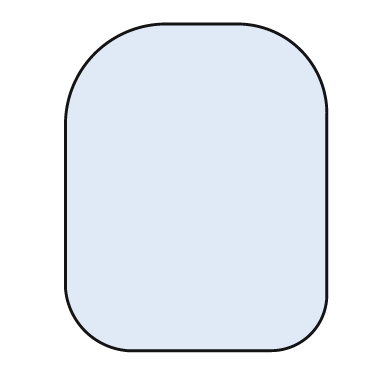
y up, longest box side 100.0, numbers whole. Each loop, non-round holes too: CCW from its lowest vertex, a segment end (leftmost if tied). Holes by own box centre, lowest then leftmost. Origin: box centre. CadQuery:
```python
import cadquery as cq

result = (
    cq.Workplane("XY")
    .moveTo(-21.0, -50.0)
    .lineTo(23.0, -50.0)
    .threePointArc((35.0, -45.0), (40.0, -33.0))
    .lineTo(40.0, 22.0)
    .threePointArc((32.0, 42.0), (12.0, 50.0))
    .lineTo(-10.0, 50.0)
    .threePointArc((-31.0, 41.0), (-40.0, 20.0))
    .lineTo(-40.0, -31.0)
    .threePointArc((-34.0, -44.0), (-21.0, -50.0))
    .close()
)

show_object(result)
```